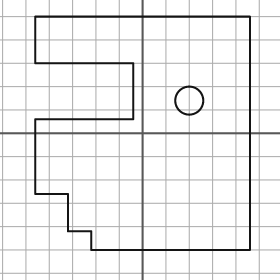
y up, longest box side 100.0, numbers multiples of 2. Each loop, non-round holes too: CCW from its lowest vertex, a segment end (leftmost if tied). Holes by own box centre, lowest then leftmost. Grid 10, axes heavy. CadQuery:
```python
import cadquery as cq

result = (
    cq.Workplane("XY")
    .moveTo(-22.0, -50.0)
    .lineTo(46.0, -50.0)
    .lineTo(46.0, 50.0)
    .lineTo(-46.0, 50.0)
    .lineTo(-46.0, 30.0)
    .lineTo(-4.0, 30.0)
    .lineTo(-4.0, 6.0)
    .lineTo(-46.0, 6.0)
    .lineTo(-46.0, -26.0)
    .lineTo(-32.0, -26.0)
    .lineTo(-32.0, -42.0)
    .lineTo(-22.0, -42.0)
    .close()
    .moveTo(20.0, 14.0)
    .circle(6.0)
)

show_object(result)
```